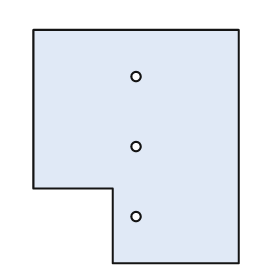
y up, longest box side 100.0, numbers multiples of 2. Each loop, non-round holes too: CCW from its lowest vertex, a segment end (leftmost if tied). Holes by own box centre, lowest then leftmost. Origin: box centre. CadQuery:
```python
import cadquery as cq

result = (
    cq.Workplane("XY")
    .moveTo(-10.0, -50.0)
    .lineTo(44.0, -50.0)
    .lineTo(44.0, 50.0)
    .lineTo(-44.0, 50.0)
    .lineTo(-44.0, -18.0)
    .lineTo(-10.0, -18.0)
    .close()
    .moveTo(0.0, -30.0)
    .circle(2.0)
    .moveTo(0.0, 0.0)
    .circle(2.0)
    .moveTo(0.0, 30.0)
    .circle(2.0)
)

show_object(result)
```